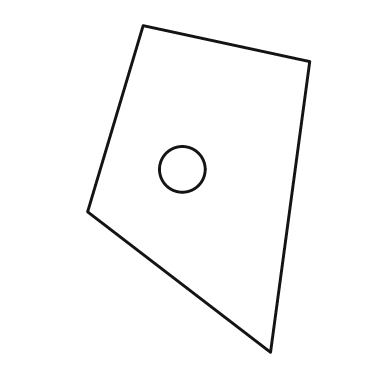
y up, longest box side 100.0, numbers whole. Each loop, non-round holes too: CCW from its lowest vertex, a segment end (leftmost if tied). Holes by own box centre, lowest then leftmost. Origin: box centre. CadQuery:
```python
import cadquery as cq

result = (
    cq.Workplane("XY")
    .moveTo(22.0, -50.0)
    .lineTo(34.0, 39.0)
    .lineTo(-17.0, 50.0)
    .lineTo(-34.0, -7.0)
    .close()
    .moveTo(-5.0, 6.0)
    .circle(7.0)
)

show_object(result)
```